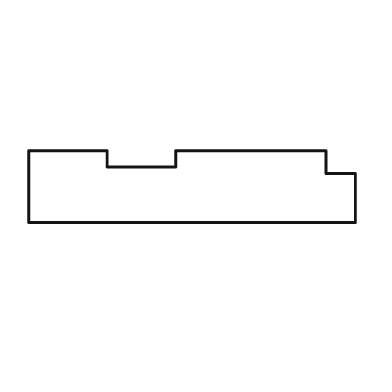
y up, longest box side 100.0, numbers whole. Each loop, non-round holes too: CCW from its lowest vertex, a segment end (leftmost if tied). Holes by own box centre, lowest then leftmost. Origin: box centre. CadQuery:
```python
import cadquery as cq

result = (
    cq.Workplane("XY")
    .moveTo(-50.0, -11.0)
    .lineTo(50.0, -11.0)
    .lineTo(50.0, 4.0)
    .lineTo(41.0, 4.0)
    .lineTo(41.0, 11.0)
    .lineTo(-5.0, 11.0)
    .lineTo(-5.0, 6.0)
    .lineTo(-26.0, 6.0)
    .lineTo(-26.0, 11.0)
    .lineTo(-50.0, 11.0)
    .close()
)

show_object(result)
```